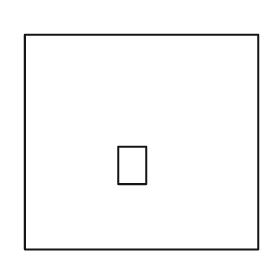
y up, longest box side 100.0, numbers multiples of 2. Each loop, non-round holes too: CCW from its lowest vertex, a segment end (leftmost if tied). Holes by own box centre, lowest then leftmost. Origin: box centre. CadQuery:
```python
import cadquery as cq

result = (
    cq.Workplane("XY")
    .moveTo(-50.0, -46.0)
    .lineTo(50.0, -46.0)
    .lineTo(50.0, 46.0)
    .lineTo(-50.0, 46.0)
    .close()
    .moveTo(-10.0, -18.0)
    .lineTo(2.0, -18.0)
    .lineTo(2.0, -2.0)
    .lineTo(-10.0, -2.0)
    .close()
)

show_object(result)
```